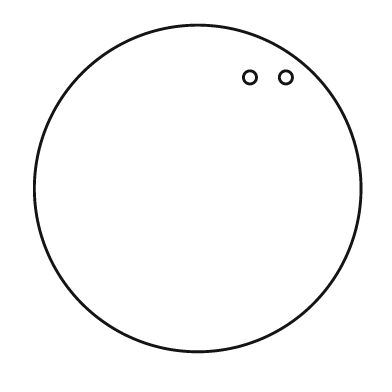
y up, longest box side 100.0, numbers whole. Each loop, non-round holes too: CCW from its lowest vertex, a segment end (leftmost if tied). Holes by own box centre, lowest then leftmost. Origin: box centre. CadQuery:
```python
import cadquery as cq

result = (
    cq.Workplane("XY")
    .moveTo(0.0, 0.0)
    .circle(50.0)
    .moveTo(16.0, 34.0)
    .circle(2.0)
    .moveTo(27.0, 34.0)
    .circle(2.0)
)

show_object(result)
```